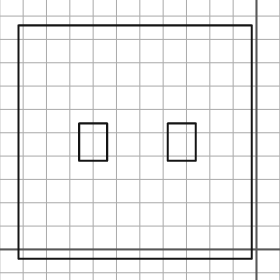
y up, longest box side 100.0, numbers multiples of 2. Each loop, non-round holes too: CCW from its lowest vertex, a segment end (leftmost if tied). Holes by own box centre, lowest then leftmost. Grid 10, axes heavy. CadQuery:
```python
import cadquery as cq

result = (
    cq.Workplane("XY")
    .moveTo(-102.0, -4.0)
    .lineTo(-2.0, -4.0)
    .lineTo(-2.0, 96.0)
    .lineTo(-102.0, 96.0)
    .close()
    .moveTo(-76.0, 38.0)
    .lineTo(-64.0, 38.0)
    .lineTo(-64.0, 54.0)
    .lineTo(-76.0, 54.0)
    .close()
    .moveTo(-38.0, 38.0)
    .lineTo(-26.0, 38.0)
    .lineTo(-26.0, 54.0)
    .lineTo(-38.0, 54.0)
    .close()
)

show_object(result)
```